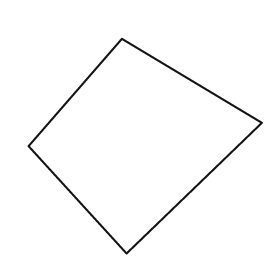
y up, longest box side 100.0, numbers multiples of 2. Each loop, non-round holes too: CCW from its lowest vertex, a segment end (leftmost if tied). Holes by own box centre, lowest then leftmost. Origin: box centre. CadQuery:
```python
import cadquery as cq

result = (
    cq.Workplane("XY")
    .moveTo(-8.0, -46.0)
    .lineTo(50.0, 10.0)
    .lineTo(-10.0, 46.0)
    .lineTo(-50.0, 0.0)
    .close()
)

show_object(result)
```